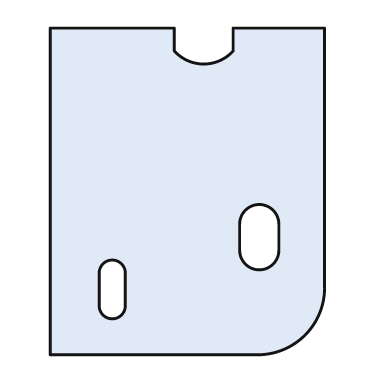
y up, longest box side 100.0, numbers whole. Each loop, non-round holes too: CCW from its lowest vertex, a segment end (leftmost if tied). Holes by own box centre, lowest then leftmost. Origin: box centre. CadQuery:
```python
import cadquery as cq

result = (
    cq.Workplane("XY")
    .moveTo(-42.0, -50.0)
    .lineTo(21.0, -50.0)
    .threePointArc((36.0, -44.0), (42.0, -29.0))
    .lineTo(42.0, 50.0)
    .lineTo(14.0, 50.0)
    .lineTo(14.0, 43.0)
    .threePointArc((5.0, 39.0), (-4.0, 43.0))
    .lineTo(-4.0, 50.0)
    .lineTo(-42.0, 50.0)
    .close()
    .moveTo(-27.0, -35.0)
    .threePointArc((-23.0, -39.0), (-19.0, -35.0))
    .lineTo(-19.0, -25.0)
    .threePointArc((-23.0, -21.0), (-27.0, -25.0))
    .close()
    .moveTo(16.0, -18.0)
    .threePointArc((22.0, -24.0), (28.0, -18.0))
    .lineTo(28.0, -10.0)
    .threePointArc((22.0, -4.0), (16.0, -10.0))
    .close()
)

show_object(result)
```